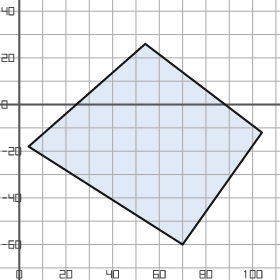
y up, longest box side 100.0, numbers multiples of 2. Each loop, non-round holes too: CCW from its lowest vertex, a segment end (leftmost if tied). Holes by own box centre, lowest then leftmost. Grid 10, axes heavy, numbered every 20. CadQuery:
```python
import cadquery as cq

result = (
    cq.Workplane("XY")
    .moveTo(70.0, -60.0)
    .lineTo(104.0, -12.0)
    .lineTo(54.0, 26.0)
    .lineTo(4.0, -18.0)
    .close()
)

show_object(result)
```